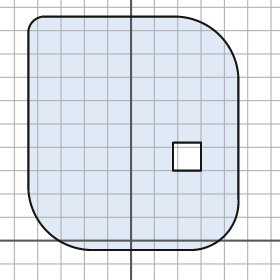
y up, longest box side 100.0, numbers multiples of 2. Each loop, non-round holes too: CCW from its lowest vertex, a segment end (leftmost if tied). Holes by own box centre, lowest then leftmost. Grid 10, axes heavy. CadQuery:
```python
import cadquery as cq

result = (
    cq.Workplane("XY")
    .moveTo(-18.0, -4.0)
    .lineTo(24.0, -4.0)
    .threePointArc((40.0, 2.0), (46.0, 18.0))
    .lineTo(46.0, 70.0)
    .threePointArc((38.0, 88.0), (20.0, 96.0))
    .lineTo(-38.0, 96.0)
    .threePointArc((-42.0, 94.0), (-44.0, 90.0))
    .lineTo(-44.0, 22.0)
    .threePointArc((-36.0, 4.0), (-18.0, -4.0))
    .close()
    .moveTo(18.0, 30.0)
    .lineTo(30.0, 30.0)
    .lineTo(30.0, 42.0)
    .lineTo(18.0, 42.0)
    .close()
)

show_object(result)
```